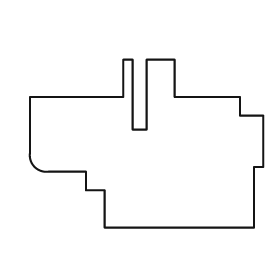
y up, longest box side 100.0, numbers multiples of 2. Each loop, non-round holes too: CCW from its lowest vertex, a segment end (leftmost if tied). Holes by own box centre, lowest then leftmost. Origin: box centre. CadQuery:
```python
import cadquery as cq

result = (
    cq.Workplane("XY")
    .moveTo(-18.0, -36.0)
    .lineTo(46.0, -36.0)
    .lineTo(46.0, -10.0)
    .lineTo(50.0, -10.0)
    .lineTo(50.0, 12.0)
    .lineTo(40.0, 12.0)
    .lineTo(40.0, 20.0)
    .lineTo(12.0, 20.0)
    .lineTo(12.0, 36.0)
    .lineTo(0.0, 36.0)
    .lineTo(0.0, 6.0)
    .lineTo(-6.0, 6.0)
    .lineTo(-6.0, 36.0)
    .lineTo(-10.0, 36.0)
    .lineTo(-10.0, 20.0)
    .lineTo(-50.0, 20.0)
    .lineTo(-50.0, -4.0)
    .threePointArc((-48.0, -10.0), (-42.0, -12.0))
    .lineTo(-26.0, -12.0)
    .lineTo(-26.0, -20.0)
    .lineTo(-18.0, -20.0)
    .close()
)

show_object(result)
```